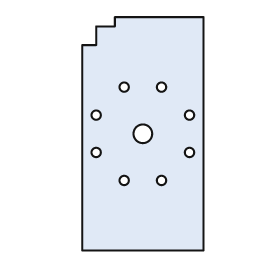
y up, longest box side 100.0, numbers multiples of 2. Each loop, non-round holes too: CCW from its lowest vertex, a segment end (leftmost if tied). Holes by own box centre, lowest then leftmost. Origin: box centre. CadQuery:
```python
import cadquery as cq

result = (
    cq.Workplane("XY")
    .moveTo(-26.0, -50.0)
    .lineTo(26.0, -50.0)
    .lineTo(26.0, 50.0)
    .lineTo(-12.0, 50.0)
    .lineTo(-12.0, 46.0)
    .lineTo(-20.0, 46.0)
    .lineTo(-20.0, 38.0)
    .lineTo(-26.0, 38.0)
    .close()
    .moveTo(-8.0, -20.0)
    .circle(2.0)
    .moveTo(8.0, -20.0)
    .circle(2.0)
    .moveTo(-20.0, -8.0)
    .circle(2.0)
    .moveTo(20.0, -8.0)
    .circle(2.0)
    .moveTo(0.0, 0.0)
    .circle(4.0)
    .moveTo(-20.0, 8.0)
    .circle(2.0)
    .moveTo(20.0, 8.0)
    .circle(2.0)
    .moveTo(-8.0, 20.0)
    .circle(2.0)
    .moveTo(8.0, 20.0)
    .circle(2.0)
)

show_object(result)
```